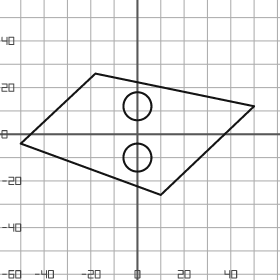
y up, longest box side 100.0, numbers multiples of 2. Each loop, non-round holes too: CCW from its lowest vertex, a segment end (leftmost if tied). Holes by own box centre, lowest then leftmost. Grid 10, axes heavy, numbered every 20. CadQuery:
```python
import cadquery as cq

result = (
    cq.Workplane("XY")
    .moveTo(10.0, -26.0)
    .lineTo(50.0, 12.0)
    .lineTo(-18.0, 26.0)
    .lineTo(-50.0, -4.0)
    .close()
    .moveTo(0.0, -10.0)
    .circle(6.0)
    .moveTo(0.0, 12.0)
    .circle(6.0)
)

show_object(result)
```